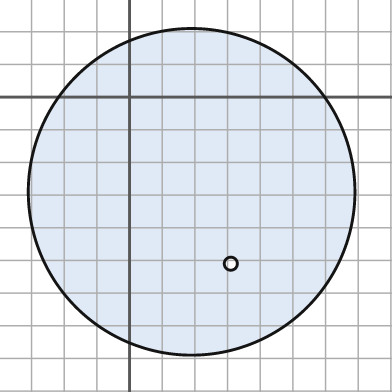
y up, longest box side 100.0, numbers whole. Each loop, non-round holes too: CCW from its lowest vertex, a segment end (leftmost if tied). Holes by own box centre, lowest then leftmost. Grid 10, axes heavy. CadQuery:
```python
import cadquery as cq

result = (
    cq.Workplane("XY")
    .moveTo(19.0, -29.0)
    .circle(50.0)
    .moveTo(31.0, -51.0)
    .circle(2.0)
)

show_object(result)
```